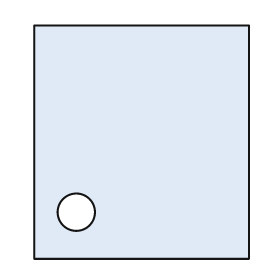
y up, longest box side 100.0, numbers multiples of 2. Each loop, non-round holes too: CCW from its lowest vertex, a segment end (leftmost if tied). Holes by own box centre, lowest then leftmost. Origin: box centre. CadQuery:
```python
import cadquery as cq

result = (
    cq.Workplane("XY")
    .moveTo(-46.0, -50.0)
    .lineTo(46.0, -50.0)
    .lineTo(46.0, 50.0)
    .lineTo(-46.0, 50.0)
    .close()
    .moveTo(-28.0, -30.0)
    .circle(8.0)
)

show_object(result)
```